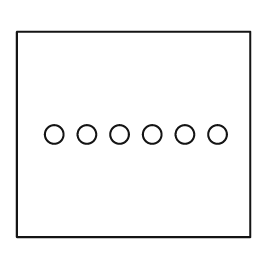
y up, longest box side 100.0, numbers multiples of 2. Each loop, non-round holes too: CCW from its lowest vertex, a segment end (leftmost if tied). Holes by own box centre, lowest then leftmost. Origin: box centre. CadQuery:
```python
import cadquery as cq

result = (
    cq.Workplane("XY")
    .moveTo(-50.0, -44.0)
    .lineTo(50.0, -44.0)
    .lineTo(50.0, 44.0)
    .lineTo(-50.0, 44.0)
    .close()
    .moveTo(-34.0, 0.0)
    .circle(4.0)
    .moveTo(-20.0, 0.0)
    .circle(4.0)
    .moveTo(-6.0, 0.0)
    .circle(4.0)
    .moveTo(8.0, 0.0)
    .circle(4.0)
    .moveTo(22.0, 0.0)
    .circle(4.0)
    .moveTo(36.0, 0.0)
    .circle(4.0)
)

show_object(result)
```